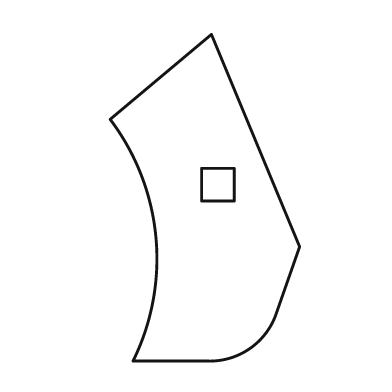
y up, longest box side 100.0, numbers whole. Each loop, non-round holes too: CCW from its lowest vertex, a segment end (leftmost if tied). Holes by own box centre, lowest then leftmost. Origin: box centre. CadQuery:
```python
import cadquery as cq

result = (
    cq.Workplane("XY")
    .moveTo(-22.0, -50.0)
    .lineTo(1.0, -50.0)
    .threePointArc((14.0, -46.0), (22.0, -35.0))
    .lineTo(29.0, -15.0)
    .lineTo(2.0, 50.0)
    .lineTo(-29.0, 24.0)
    .threePointArc((-15.0, -12.0), (-22.0, -50.0))
    .close()
    .moveTo(-1.0, -1.0)
    .lineTo(9.0, -1.0)
    .lineTo(9.0, 9.0)
    .lineTo(-1.0, 9.0)
    .close()
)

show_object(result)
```